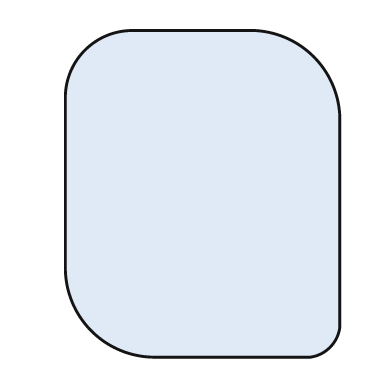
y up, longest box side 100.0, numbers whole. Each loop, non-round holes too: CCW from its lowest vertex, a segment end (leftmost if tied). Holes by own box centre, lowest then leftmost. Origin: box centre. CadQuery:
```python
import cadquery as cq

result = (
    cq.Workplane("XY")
    .moveTo(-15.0, -50.0)
    .lineTo(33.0, -50.0)
    .threePointArc((39.0, -47.0), (42.0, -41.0))
    .lineTo(42.0, 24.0)
    .threePointArc((34.0, 42.0), (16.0, 50.0))
    .lineTo(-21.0, 50.0)
    .threePointArc((-36.0, 44.0), (-42.0, 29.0))
    .lineTo(-42.0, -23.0)
    .threePointArc((-34.0, -42.0), (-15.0, -50.0))
    .close()
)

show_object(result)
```